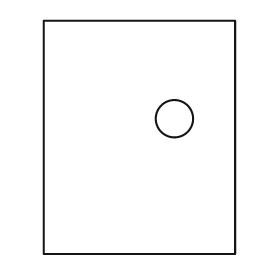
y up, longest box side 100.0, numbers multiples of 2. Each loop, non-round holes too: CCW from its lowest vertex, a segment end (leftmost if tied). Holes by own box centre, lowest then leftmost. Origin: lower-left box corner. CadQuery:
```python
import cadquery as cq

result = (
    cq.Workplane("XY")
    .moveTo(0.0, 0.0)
    .lineTo(82.0, 0.0)
    .lineTo(82.0, 100.0)
    .lineTo(0.0, 100.0)
    .close()
    .moveTo(56.0, 58.0)
    .circle(8.0)
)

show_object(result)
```